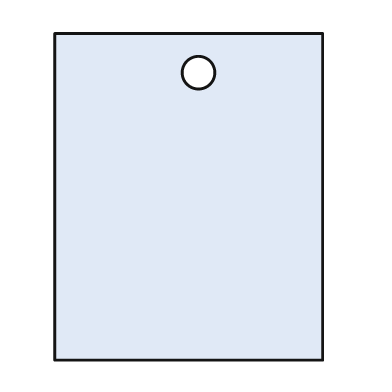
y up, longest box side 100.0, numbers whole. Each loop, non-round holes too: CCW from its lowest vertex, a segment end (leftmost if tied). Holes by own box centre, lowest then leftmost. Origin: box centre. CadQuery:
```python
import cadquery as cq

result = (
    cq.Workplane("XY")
    .moveTo(-41.0, -50.0)
    .lineTo(41.0, -50.0)
    .lineTo(41.0, 50.0)
    .lineTo(-41.0, 50.0)
    .close()
    .moveTo(3.0, 38.0)
    .circle(5.0)
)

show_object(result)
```